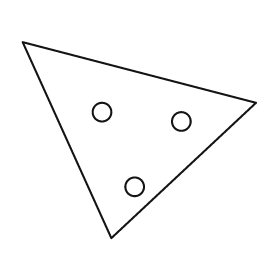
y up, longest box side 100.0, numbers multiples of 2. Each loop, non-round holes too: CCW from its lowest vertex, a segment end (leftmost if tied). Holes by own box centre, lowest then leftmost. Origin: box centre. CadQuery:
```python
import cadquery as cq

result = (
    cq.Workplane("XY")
    .moveTo(-12.0, -42.0)
    .lineTo(50.0, 16.0)
    .lineTo(-50.0, 42.0)
    .close()
    .moveTo(-2.0, -20.0)
    .circle(4.0)
    .moveTo(18.0, 8.0)
    .circle(4.0)
    .moveTo(-16.0, 12.0)
    .circle(4.0)
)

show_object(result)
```